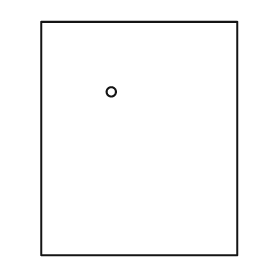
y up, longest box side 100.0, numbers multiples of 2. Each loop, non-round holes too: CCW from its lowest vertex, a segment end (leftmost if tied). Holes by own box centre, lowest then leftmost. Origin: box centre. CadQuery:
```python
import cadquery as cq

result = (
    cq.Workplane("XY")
    .moveTo(-42.0, -50.0)
    .lineTo(42.0, -50.0)
    .lineTo(42.0, 50.0)
    .lineTo(-42.0, 50.0)
    .close()
    .moveTo(-12.0, 20.0)
    .circle(2.0)
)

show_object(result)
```